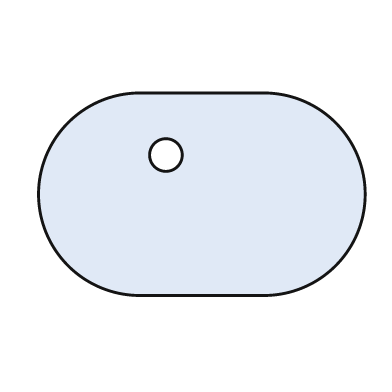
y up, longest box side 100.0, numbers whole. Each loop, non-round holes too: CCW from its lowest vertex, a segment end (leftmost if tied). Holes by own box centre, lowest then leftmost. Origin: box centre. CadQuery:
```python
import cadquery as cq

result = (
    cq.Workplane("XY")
    .moveTo(-19.0, -31.0)
    .lineTo(19.0, -31.0)
    .threePointArc((50.0, 0.0), (19.0, 31.0))
    .lineTo(-19.0, 31.0)
    .threePointArc((-50.0, 0.0), (-19.0, -31.0))
    .close()
    .moveTo(-11.0, 12.0)
    .circle(5.0)
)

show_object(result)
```